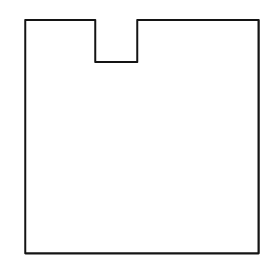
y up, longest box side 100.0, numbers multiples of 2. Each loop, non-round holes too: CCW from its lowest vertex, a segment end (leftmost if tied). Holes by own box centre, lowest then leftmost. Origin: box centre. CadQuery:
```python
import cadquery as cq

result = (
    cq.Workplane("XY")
    .moveTo(-50.0, -50.0)
    .lineTo(50.0, -50.0)
    .lineTo(50.0, 50.0)
    .lineTo(-2.0, 50.0)
    .lineTo(-2.0, 32.0)
    .lineTo(-20.0, 32.0)
    .lineTo(-20.0, 50.0)
    .lineTo(-50.0, 50.0)
    .close()
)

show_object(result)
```